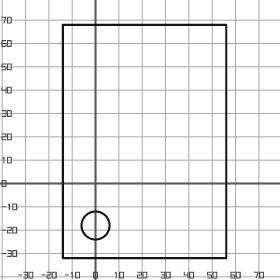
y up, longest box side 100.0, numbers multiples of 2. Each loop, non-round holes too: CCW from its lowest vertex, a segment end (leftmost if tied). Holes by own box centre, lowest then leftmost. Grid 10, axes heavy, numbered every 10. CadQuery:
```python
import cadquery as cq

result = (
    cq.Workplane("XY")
    .moveTo(-14.0, -32.0)
    .lineTo(56.0, -32.0)
    .lineTo(56.0, 68.0)
    .lineTo(-14.0, 68.0)
    .close()
    .moveTo(0.0, -18.0)
    .circle(6.0)
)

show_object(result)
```